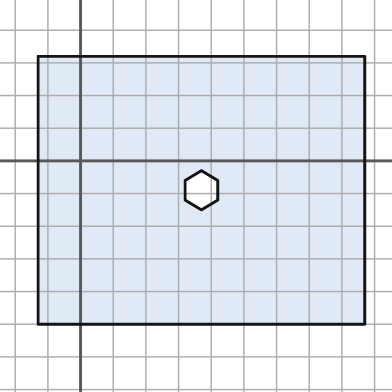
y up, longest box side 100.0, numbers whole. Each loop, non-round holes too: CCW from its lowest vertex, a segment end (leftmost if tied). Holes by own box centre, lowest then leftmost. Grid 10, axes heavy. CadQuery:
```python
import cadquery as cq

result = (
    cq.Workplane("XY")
    .moveTo(-13.0, -50.0)
    .lineTo(87.0, -50.0)
    .lineTo(87.0, 32.0)
    .lineTo(-13.0, 32.0)
    .close()
    .moveTo(37.0, -15.0)
    .lineTo(42.0, -12.0)
    .lineTo(42.0, -6.0)
    .lineTo(37.0, -3.0)
    .lineTo(32.0, -6.0)
    .lineTo(32.0, -12.0)
    .close()
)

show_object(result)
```